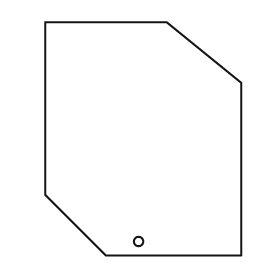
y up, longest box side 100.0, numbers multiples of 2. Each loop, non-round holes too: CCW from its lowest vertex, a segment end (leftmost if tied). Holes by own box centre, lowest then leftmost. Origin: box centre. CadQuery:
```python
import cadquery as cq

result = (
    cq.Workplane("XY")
    .moveTo(-16.0, -50.0)
    .lineTo(42.0, -50.0)
    .lineTo(42.0, 24.0)
    .lineTo(10.0, 50.0)
    .lineTo(-42.0, 50.0)
    .lineTo(-42.0, -24.0)
    .close()
    .moveTo(-2.0, -44.0)
    .circle(2.0)
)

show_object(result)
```